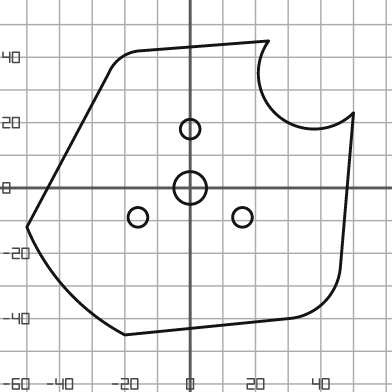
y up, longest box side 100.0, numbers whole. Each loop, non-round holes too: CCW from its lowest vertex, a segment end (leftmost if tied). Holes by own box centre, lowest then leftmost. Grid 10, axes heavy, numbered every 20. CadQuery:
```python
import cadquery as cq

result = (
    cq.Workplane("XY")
    .moveTo(-20.0, -45.0)
    .lineTo(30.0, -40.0)
    .threePointArc((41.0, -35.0), (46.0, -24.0))
    .lineTo(50.0, 23.0)
    .threePointArc((27.0, 22.0), (24.0, 45.0))
    .lineTo(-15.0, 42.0)
    .threePointArc((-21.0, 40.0), (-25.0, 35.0))
    .lineTo(-50.0, -12.0)
    .threePointArc((-38.0, -31.0), (-20.0, -45.0))
    .close()
    .moveTo(-16.0, -9.0)
    .circle(3.0)
    .moveTo(16.0, -9.0)
    .circle(3.0)
    .moveTo(0.0, 0.0)
    .circle(5.0)
    .moveTo(0.0, 18.0)
    .circle(3.0)
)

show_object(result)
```